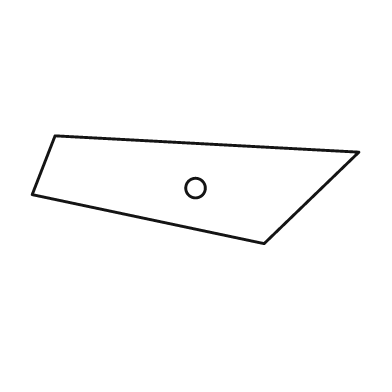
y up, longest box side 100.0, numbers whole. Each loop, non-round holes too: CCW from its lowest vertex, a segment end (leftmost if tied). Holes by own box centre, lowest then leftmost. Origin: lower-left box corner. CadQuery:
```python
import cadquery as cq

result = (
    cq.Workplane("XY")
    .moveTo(71.0, 0.0)
    .lineTo(100.0, 28.0)
    .lineTo(7.0, 33.0)
    .lineTo(0.0, 15.0)
    .close()
    .moveTo(50.0, 17.0)
    .circle(3.0)
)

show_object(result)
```